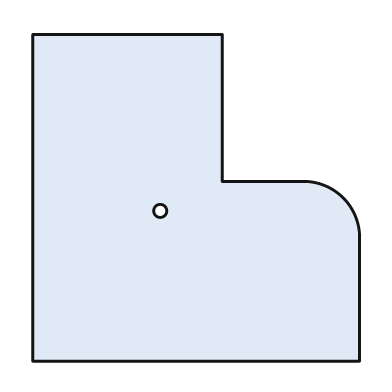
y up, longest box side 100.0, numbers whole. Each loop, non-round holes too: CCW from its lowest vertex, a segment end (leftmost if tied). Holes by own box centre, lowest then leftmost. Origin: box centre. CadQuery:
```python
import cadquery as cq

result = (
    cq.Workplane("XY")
    .moveTo(-50.0, -50.0)
    .lineTo(50.0, -50.0)
    .lineTo(50.0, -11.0)
    .threePointArc((45.0, 0.0), (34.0, 5.0))
    .lineTo(8.0, 5.0)
    .lineTo(8.0, 50.0)
    .lineTo(-50.0, 50.0)
    .close()
    .moveTo(-11.0, -4.0)
    .circle(2.0)
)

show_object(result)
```